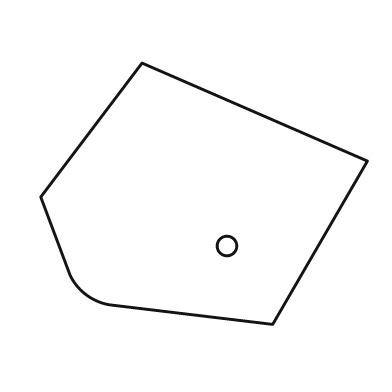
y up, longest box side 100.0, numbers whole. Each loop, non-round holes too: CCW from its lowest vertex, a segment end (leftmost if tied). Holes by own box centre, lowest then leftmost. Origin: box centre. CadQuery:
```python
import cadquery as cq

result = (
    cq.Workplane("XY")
    .moveTo(21.0, -40.0)
    .lineTo(50.0, 10.0)
    .lineTo(-19.0, 40.0)
    .lineTo(-50.0, -1.0)
    .lineTo(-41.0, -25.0)
    .threePointArc((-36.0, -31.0), (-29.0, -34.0))
    .close()
    .moveTo(7.0, -16.0)
    .circle(3.0)
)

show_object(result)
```